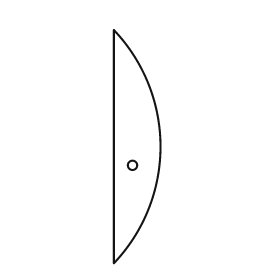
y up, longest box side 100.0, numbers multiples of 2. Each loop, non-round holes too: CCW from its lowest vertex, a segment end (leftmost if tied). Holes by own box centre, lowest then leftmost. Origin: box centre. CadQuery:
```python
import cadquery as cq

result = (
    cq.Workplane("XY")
    .moveTo(-10.0, -50.0)
    .threePointArc((10.0, 0.0), (-10.0, 50.0))
    .close()
    .moveTo(-2.0, -8.0)
    .circle(2.0)
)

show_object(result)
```